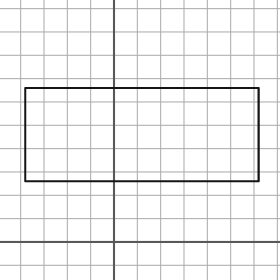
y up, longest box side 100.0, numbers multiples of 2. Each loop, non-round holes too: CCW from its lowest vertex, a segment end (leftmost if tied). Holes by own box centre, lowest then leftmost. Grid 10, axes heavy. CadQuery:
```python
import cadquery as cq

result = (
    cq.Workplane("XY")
    .moveTo(-38.0, 26.0)
    .lineTo(62.0, 26.0)
    .lineTo(62.0, 66.0)
    .lineTo(-38.0, 66.0)
    .close()
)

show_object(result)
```